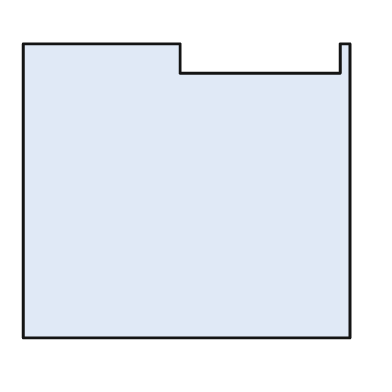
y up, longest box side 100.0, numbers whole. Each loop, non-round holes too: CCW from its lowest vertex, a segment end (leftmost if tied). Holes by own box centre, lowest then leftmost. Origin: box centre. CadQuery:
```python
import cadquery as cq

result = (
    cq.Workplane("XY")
    .moveTo(-50.0, -45.0)
    .lineTo(50.0, -45.0)
    .lineTo(50.0, 45.0)
    .lineTo(47.0, 45.0)
    .lineTo(47.0, 36.0)
    .lineTo(-2.0, 36.0)
    .lineTo(-2.0, 45.0)
    .lineTo(-50.0, 45.0)
    .close()
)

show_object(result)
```